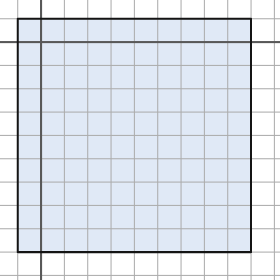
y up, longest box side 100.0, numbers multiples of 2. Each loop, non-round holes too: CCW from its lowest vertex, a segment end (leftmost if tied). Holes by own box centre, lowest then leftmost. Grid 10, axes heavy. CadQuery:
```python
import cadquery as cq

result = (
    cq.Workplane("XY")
    .moveTo(-10.0, -90.0)
    .lineTo(90.0, -90.0)
    .lineTo(90.0, 10.0)
    .lineTo(-10.0, 10.0)
    .close()
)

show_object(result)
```